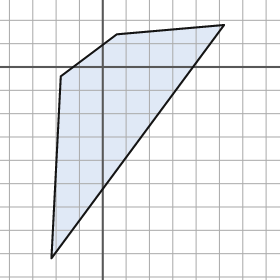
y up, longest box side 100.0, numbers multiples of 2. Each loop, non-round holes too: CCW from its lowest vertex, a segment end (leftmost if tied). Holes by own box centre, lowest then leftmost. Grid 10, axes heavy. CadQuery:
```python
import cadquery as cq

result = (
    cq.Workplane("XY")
    .moveTo(-22.0, -82.0)
    .lineTo(52.0, 18.0)
    .lineTo(6.0, 14.0)
    .lineTo(-18.0, -4.0)
    .close()
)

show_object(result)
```